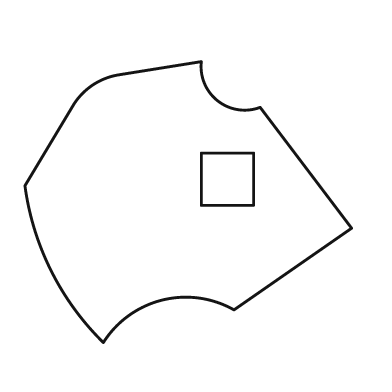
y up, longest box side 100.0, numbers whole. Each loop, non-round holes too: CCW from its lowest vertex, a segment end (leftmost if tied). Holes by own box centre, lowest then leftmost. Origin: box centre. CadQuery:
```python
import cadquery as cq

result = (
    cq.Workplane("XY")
    .moveTo(-26.0, -43.0)
    .threePointArc((-8.0, -30.0), (14.0, -33.0))
    .lineTo(50.0, -8.0)
    .lineTo(22.0, 29.0)
    .threePointArc((9.0, 31.0), (4.0, 43.0))
    .lineTo(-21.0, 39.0)
    .threePointArc((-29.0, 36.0), (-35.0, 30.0))
    .lineTo(-50.0, 5.0)
    .threePointArc((-42.0, -21.0), (-26.0, -43.0))
    .close()
    .moveTo(4.0, -1.0)
    .lineTo(20.0, -1.0)
    .lineTo(20.0, 15.0)
    .lineTo(4.0, 15.0)
    .close()
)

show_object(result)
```